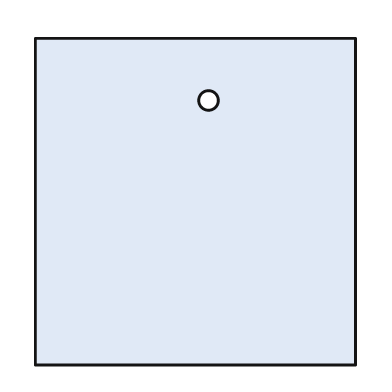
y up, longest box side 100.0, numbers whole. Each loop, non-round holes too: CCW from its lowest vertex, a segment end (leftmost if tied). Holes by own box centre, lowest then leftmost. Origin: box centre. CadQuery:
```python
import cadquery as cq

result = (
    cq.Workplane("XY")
    .moveTo(-49.0, -50.0)
    .lineTo(49.0, -50.0)
    .lineTo(49.0, 50.0)
    .lineTo(-49.0, 50.0)
    .close()
    .moveTo(4.0, 31.0)
    .circle(3.0)
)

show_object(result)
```